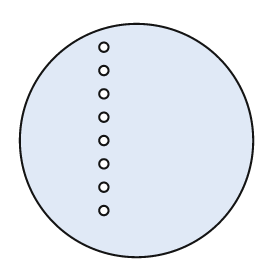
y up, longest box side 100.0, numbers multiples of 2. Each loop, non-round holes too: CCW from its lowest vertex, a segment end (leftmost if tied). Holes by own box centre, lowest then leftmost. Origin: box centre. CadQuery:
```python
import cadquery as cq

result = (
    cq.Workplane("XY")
    .moveTo(0.0, 0.0)
    .circle(50.0)
    .moveTo(-14.0, -30.0)
    .circle(2.0)
    .moveTo(-14.0, -20.0)
    .circle(2.0)
    .moveTo(-14.0, -10.0)
    .circle(2.0)
    .moveTo(-14.0, 0.0)
    .circle(2.0)
    .moveTo(-14.0, 10.0)
    .circle(2.0)
    .moveTo(-14.0, 20.0)
    .circle(2.0)
    .moveTo(-14.0, 30.0)
    .circle(2.0)
    .moveTo(-14.0, 40.0)
    .circle(2.0)
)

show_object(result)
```